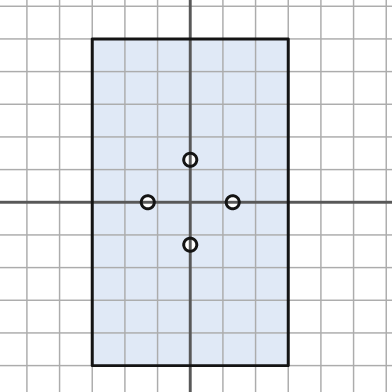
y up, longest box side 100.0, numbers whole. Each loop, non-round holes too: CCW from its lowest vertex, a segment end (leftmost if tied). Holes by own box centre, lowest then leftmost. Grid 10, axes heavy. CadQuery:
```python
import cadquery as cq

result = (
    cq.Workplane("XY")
    .moveTo(-30.0, -50.0)
    .lineTo(30.0, -50.0)
    .lineTo(30.0, 50.0)
    .lineTo(-30.0, 50.0)
    .close()
    .moveTo(0.0, -13.0)
    .circle(2.0)
    .moveTo(-13.0, 0.0)
    .circle(2.0)
    .moveTo(13.0, 0.0)
    .circle(2.0)
    .moveTo(0.0, 13.0)
    .circle(2.0)
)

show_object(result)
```